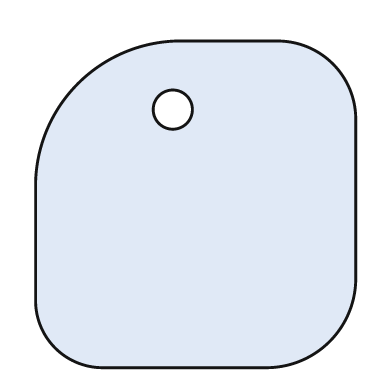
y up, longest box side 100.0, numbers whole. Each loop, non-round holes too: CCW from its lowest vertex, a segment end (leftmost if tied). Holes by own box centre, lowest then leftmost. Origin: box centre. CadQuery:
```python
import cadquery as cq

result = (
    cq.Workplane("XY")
    .moveTo(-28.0, -50.0)
    .lineTo(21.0, -50.0)
    .threePointArc((41.0, -42.0), (49.0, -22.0))
    .lineTo(49.0, 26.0)
    .threePointArc((42.0, 43.0), (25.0, 50.0))
    .lineTo(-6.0, 50.0)
    .threePointArc((-36.0, 37.0), (-49.0, 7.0))
    .lineTo(-49.0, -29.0)
    .threePointArc((-43.0, -44.0), (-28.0, -50.0))
    .close()
    .moveTo(-7.0, 29.0)
    .circle(6.0)
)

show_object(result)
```